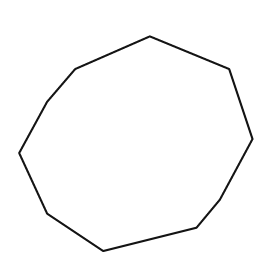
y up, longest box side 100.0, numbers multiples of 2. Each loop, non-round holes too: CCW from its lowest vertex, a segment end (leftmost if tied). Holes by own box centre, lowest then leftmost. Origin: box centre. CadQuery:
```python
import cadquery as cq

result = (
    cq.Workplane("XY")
    .moveTo(-14.0, -46.0)
    .lineTo(26.0, -36.0)
    .lineTo(36.0, -24.0)
    .lineTo(50.0, 2.0)
    .lineTo(40.0, 32.0)
    .lineTo(6.0, 46.0)
    .lineTo(-26.0, 32.0)
    .lineTo(-38.0, 18.0)
    .lineTo(-50.0, -4.0)
    .lineTo(-38.0, -30.0)
    .close()
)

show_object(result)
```